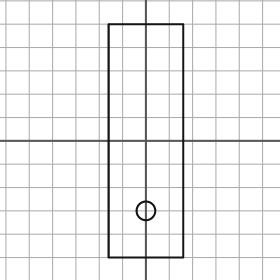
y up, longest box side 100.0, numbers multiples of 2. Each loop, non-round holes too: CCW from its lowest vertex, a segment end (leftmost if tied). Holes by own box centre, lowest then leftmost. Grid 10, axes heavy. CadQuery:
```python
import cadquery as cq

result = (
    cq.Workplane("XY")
    .moveTo(-16.0, -50.0)
    .lineTo(16.0, -50.0)
    .lineTo(16.0, 50.0)
    .lineTo(-16.0, 50.0)
    .close()
    .moveTo(0.0, -30.0)
    .circle(4.0)
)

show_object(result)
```